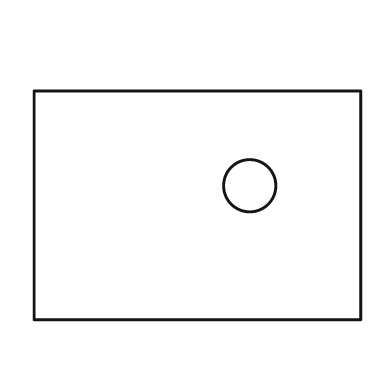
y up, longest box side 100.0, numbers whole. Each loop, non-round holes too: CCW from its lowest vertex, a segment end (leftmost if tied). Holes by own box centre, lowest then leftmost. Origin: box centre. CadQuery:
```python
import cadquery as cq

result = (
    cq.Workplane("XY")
    .moveTo(-50.0, -35.0)
    .lineTo(50.0, -35.0)
    .lineTo(50.0, 35.0)
    .lineTo(-50.0, 35.0)
    .close()
    .moveTo(16.0, 6.0)
    .circle(8.0)
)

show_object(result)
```